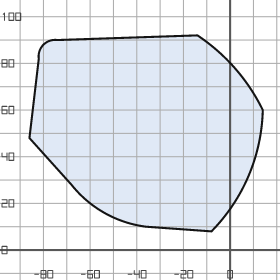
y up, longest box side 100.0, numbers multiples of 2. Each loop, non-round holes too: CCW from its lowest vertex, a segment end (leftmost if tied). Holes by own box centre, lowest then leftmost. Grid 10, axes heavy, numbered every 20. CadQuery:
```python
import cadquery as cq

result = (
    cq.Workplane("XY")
    .moveTo(-8.0, 8.0)
    .threePointArc((8.0, 32.0), (14.0, 60.0))
    .threePointArc((2.0, 78.0), (-14.0, 92.0))
    .lineTo(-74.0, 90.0)
    .threePointArc((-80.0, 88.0), (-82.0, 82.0))
    .lineTo(-86.0, 48.0)
    .lineTo(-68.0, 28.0)
    .threePointArc((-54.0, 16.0), (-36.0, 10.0))
    .close()
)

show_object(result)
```